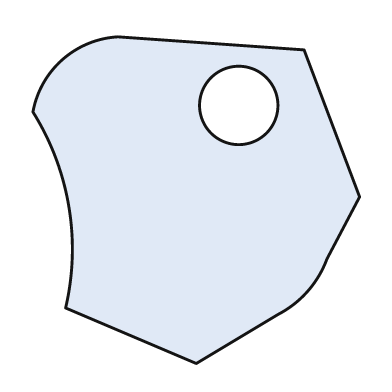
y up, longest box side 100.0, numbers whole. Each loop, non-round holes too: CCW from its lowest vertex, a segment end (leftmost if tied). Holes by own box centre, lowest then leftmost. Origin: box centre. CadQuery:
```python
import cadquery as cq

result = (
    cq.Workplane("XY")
    .moveTo(0.0, -50.0)
    .lineTo(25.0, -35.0)
    .threePointArc((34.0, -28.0), (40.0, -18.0))
    .lineTo(50.0, 1.0)
    .lineTo(33.0, 46.0)
    .lineTo(-24.0, 50.0)
    .threePointArc((-41.0, 43.0), (-50.0, 27.0))
    .threePointArc((-39.0, -2.0), (-40.0, -33.0))
    .close()
    .moveTo(13.0, 29.0)
    .circle(12.0)
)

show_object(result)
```